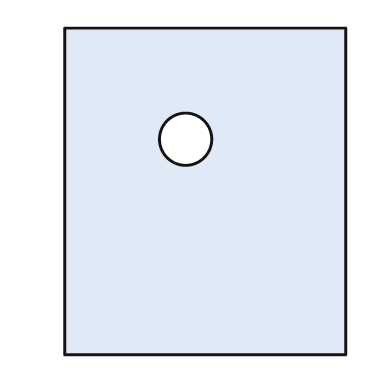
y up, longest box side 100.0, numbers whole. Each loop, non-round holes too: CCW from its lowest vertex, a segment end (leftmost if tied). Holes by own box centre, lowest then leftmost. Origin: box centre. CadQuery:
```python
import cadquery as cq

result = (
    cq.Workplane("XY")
    .moveTo(-43.0, -50.0)
    .lineTo(43.0, -50.0)
    .lineTo(43.0, 50.0)
    .lineTo(-43.0, 50.0)
    .close()
    .moveTo(-6.0, 16.0)
    .circle(8.0)
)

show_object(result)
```